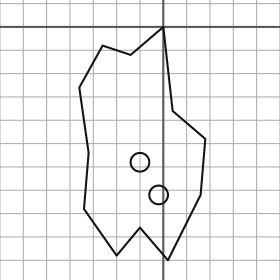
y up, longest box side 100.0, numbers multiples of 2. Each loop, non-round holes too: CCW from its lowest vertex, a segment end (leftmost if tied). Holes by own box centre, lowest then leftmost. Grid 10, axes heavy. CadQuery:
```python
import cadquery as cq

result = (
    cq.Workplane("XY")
    .moveTo(2.0, -100.0)
    .lineTo(16.0, -72.0)
    .lineTo(18.0, -48.0)
    .lineTo(4.0, -36.0)
    .lineTo(0.0, 0.0)
    .lineTo(-14.0, -12.0)
    .lineTo(-26.0, -8.0)
    .lineTo(-36.0, -26.0)
    .lineTo(-32.0, -54.0)
    .lineTo(-34.0, -78.0)
    .lineTo(-20.0, -98.0)
    .lineTo(-10.0, -86.0)
    .close()
    .moveTo(-2.0, -72.0)
    .circle(4.0)
    .moveTo(-10.0, -58.0)
    .circle(4.0)
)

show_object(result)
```